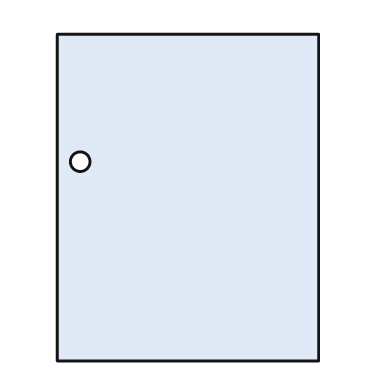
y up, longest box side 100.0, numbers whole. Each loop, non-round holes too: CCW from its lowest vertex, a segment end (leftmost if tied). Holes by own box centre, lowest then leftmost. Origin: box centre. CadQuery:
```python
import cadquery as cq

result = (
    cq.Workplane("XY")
    .moveTo(-40.0, -50.0)
    .lineTo(40.0, -50.0)
    .lineTo(40.0, 50.0)
    .lineTo(-40.0, 50.0)
    .close()
    .moveTo(-33.0, 11.0)
    .circle(3.0)
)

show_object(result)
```